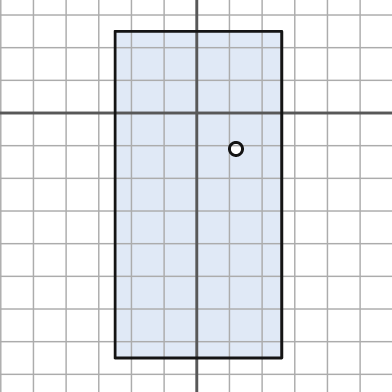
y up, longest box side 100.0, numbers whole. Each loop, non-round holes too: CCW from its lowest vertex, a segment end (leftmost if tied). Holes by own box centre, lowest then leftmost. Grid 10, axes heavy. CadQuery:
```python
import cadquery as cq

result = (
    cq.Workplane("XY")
    .moveTo(-25.0, -75.0)
    .lineTo(26.0, -75.0)
    .lineTo(26.0, 25.0)
    .lineTo(-25.0, 25.0)
    .close()
    .moveTo(12.0, -11.0)
    .circle(2.0)
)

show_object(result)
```